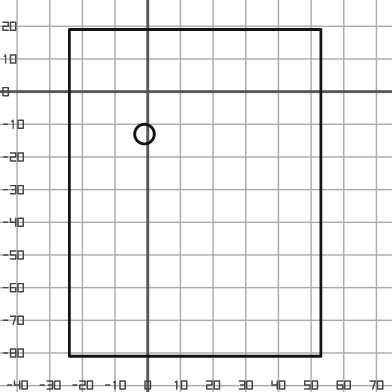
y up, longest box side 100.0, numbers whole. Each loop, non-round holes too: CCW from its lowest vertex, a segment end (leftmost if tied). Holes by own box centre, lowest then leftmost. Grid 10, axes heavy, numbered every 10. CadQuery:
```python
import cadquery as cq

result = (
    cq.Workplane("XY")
    .moveTo(-24.0, -81.0)
    .lineTo(53.0, -81.0)
    .lineTo(53.0, 19.0)
    .lineTo(-24.0, 19.0)
    .close()
    .moveTo(-1.0, -13.0)
    .circle(3.0)
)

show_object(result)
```